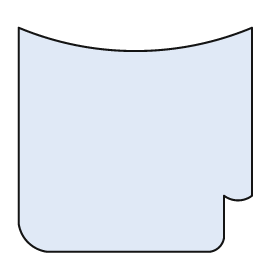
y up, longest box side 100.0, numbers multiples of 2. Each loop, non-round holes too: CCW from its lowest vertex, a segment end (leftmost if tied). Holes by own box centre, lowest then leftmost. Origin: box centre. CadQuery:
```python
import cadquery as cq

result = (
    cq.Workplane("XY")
    .moveTo(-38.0, -48.0)
    .lineTo(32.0, -48.0)
    .threePointArc((36.0, -46.0), (38.0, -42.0))
    .lineTo(38.0, -24.0)
    .threePointArc((44.0, -26.0), (50.0, -24.0))
    .lineTo(50.0, 48.0)
    .threePointArc((0.0, 38.0), (-50.0, 48.0))
    .lineTo(-50.0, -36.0)
    .threePointArc((-46.0, -44.0), (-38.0, -48.0))
    .close()
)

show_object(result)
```